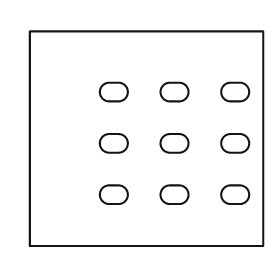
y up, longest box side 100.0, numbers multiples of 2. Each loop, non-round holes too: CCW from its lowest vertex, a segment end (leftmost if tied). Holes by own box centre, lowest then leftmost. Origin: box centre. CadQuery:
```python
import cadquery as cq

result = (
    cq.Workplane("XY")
    .moveTo(-50.0, -46.0)
    .lineTo(50.0, -46.0)
    .lineTo(50.0, 46.0)
    .lineTo(-50.0, 46.0)
    .close()
    .moveTo(-16.0, -28.0)
    .lineTo(-12.0, -28.0)
    .threePointArc((-8.0, -24.0), (-12.0, -20.0))
    .lineTo(-16.0, -20.0)
    .threePointArc((-20.0, -24.0), (-16.0, -28.0))
    .close()
    .moveTo(10.0, -28.0)
    .lineTo(14.0, -28.0)
    .threePointArc((18.0, -24.0), (14.0, -20.0))
    .lineTo(10.0, -20.0)
    .threePointArc((6.0, -24.0), (10.0, -28.0))
    .close()
    .moveTo(36.0, -28.0)
    .lineTo(40.0, -28.0)
    .threePointArc((44.0, -24.0), (40.0, -20.0))
    .lineTo(36.0, -20.0)
    .threePointArc((32.0, -24.0), (36.0, -28.0))
    .close()
    .moveTo(-16.0, -6.0)
    .lineTo(-12.0, -6.0)
    .threePointArc((-8.0, -2.0), (-12.0, 2.0))
    .lineTo(-16.0, 2.0)
    .threePointArc((-20.0, -2.0), (-16.0, -6.0))
    .close()
    .moveTo(10.0, -6.0)
    .lineTo(14.0, -6.0)
    .threePointArc((18.0, -2.0), (14.0, 2.0))
    .lineTo(10.0, 2.0)
    .threePointArc((6.0, -2.0), (10.0, -6.0))
    .close()
    .moveTo(36.0, -6.0)
    .lineTo(40.0, -6.0)
    .threePointArc((44.0, -2.0), (40.0, 2.0))
    .lineTo(36.0, 2.0)
    .threePointArc((32.0, -2.0), (36.0, -6.0))
    .close()
    .moveTo(-16.0, 16.0)
    .lineTo(-12.0, 16.0)
    .threePointArc((-8.0, 20.0), (-12.0, 24.0))
    .lineTo(-16.0, 24.0)
    .threePointArc((-20.0, 20.0), (-16.0, 16.0))
    .close()
    .moveTo(10.0, 16.0)
    .lineTo(14.0, 16.0)
    .threePointArc((18.0, 20.0), (14.0, 24.0))
    .lineTo(10.0, 24.0)
    .threePointArc((6.0, 20.0), (10.0, 16.0))
    .close()
    .moveTo(36.0, 16.0)
    .lineTo(40.0, 16.0)
    .threePointArc((44.0, 20.0), (40.0, 24.0))
    .lineTo(36.0, 24.0)
    .threePointArc((32.0, 20.0), (36.0, 16.0))
    .close()
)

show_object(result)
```